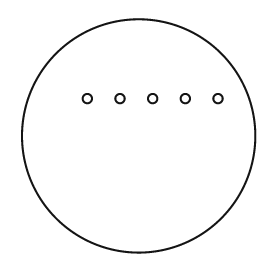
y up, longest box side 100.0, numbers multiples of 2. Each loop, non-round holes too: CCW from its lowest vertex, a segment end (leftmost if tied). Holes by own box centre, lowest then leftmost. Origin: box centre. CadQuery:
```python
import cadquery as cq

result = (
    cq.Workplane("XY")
    .moveTo(0.0, 0.0)
    .circle(50.0)
    .moveTo(-22.0, 16.0)
    .circle(2.0)
    .moveTo(-8.0, 16.0)
    .circle(2.0)
    .moveTo(6.0, 16.0)
    .circle(2.0)
    .moveTo(20.0, 16.0)
    .circle(2.0)
    .moveTo(34.0, 16.0)
    .circle(2.0)
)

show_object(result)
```